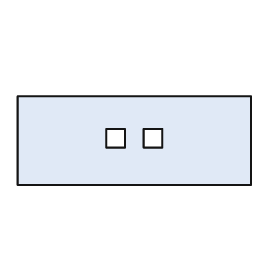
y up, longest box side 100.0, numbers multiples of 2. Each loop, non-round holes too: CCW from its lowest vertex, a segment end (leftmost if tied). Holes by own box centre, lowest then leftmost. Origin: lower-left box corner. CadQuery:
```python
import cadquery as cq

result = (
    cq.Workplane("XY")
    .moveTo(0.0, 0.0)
    .lineTo(100.0, 0.0)
    .lineTo(100.0, 38.0)
    .lineTo(0.0, 38.0)
    .close()
    .moveTo(38.0, 16.0)
    .lineTo(46.0, 16.0)
    .lineTo(46.0, 24.0)
    .lineTo(38.0, 24.0)
    .close()
    .moveTo(54.0, 16.0)
    .lineTo(62.0, 16.0)
    .lineTo(62.0, 24.0)
    .lineTo(54.0, 24.0)
    .close()
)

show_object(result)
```